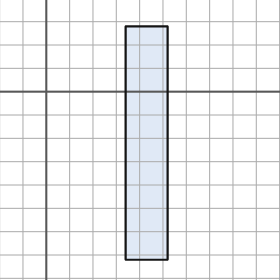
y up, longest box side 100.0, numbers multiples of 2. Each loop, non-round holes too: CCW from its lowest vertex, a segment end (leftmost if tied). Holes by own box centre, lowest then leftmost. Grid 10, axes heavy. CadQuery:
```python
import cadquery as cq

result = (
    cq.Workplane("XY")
    .moveTo(34.0, -72.0)
    .lineTo(52.0, -72.0)
    .lineTo(52.0, 28.0)
    .lineTo(34.0, 28.0)
    .close()
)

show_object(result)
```